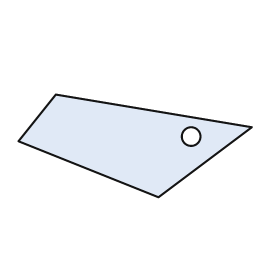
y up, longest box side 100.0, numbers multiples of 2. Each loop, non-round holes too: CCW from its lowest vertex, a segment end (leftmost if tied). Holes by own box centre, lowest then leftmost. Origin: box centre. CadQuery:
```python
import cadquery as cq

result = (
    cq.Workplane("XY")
    .moveTo(10.0, -22.0)
    .lineTo(50.0, 8.0)
    .lineTo(-34.0, 22.0)
    .lineTo(-50.0, 2.0)
    .close()
    .moveTo(24.0, 4.0)
    .circle(4.0)
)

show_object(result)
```